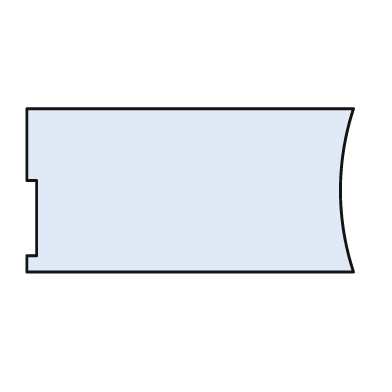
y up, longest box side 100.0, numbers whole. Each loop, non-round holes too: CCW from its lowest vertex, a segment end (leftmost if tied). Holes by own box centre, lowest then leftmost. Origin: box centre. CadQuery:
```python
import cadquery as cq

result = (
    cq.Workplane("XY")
    .moveTo(-50.0, -25.0)
    .lineTo(50.0, -25.0)
    .threePointArc((46.0, 0.0), (50.0, 25.0))
    .lineTo(-50.0, 25.0)
    .lineTo(-50.0, 3.0)
    .lineTo(-47.0, 3.0)
    .lineTo(-47.0, -20.0)
    .lineTo(-50.0, -20.0)
    .close()
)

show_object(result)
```